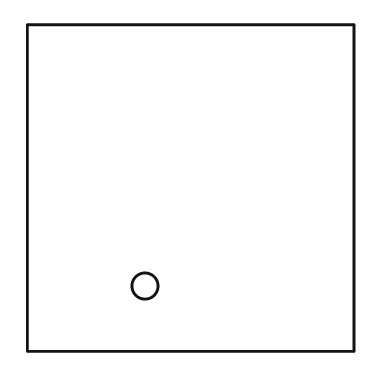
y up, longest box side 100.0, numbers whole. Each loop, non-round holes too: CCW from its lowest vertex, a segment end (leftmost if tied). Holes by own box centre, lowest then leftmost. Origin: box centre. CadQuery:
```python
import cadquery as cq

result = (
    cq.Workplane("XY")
    .moveTo(-50.0, -50.0)
    .lineTo(50.0, -50.0)
    .lineTo(50.0, 50.0)
    .lineTo(-50.0, 50.0)
    .close()
    .moveTo(-14.0, -30.0)
    .circle(4.0)
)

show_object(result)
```